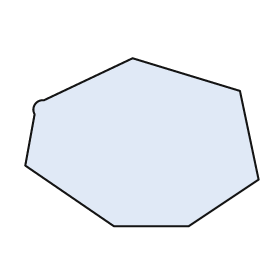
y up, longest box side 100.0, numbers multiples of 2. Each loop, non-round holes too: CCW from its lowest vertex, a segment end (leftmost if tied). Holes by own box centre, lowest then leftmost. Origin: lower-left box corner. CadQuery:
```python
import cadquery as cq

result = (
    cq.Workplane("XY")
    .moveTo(38.0, 0.0)
    .lineTo(70.0, 0.0)
    .lineTo(100.0, 20.0)
    .lineTo(92.0, 58.0)
    .lineTo(46.0, 72.0)
    .lineTo(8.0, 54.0)
    .threePointArc((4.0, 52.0), (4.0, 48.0))
    .lineTo(0.0, 26.0)
    .close()
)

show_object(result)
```